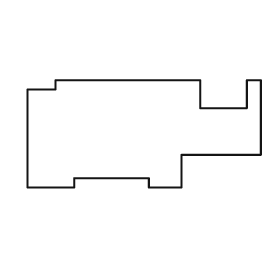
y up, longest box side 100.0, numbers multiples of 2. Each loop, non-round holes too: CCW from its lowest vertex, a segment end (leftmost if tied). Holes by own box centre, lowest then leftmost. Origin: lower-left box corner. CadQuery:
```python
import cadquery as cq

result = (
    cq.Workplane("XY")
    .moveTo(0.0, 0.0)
    .lineTo(20.0, 0.0)
    .lineTo(20.0, 4.0)
    .lineTo(52.0, 4.0)
    .lineTo(52.0, 0.0)
    .lineTo(66.0, 0.0)
    .lineTo(66.0, 14.0)
    .lineTo(100.0, 14.0)
    .lineTo(100.0, 46.0)
    .lineTo(94.0, 46.0)
    .lineTo(94.0, 34.0)
    .lineTo(74.0, 34.0)
    .lineTo(74.0, 46.0)
    .lineTo(12.0, 46.0)
    .lineTo(12.0, 42.0)
    .lineTo(0.0, 42.0)
    .close()
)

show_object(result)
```